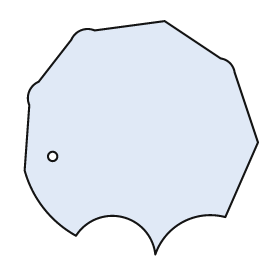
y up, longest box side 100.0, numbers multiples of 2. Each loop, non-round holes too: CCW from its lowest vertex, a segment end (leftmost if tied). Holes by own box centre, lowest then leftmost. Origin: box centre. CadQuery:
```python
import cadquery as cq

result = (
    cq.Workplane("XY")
    .moveTo(6.0, -50.0)
    .threePointArc((18.0, -36.0), (36.0, -34.0))
    .lineTo(50.0, -2.0)
    .lineTo(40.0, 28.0)
    .threePointArc((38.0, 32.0), (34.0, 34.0))
    .lineTo(10.0, 50.0)
    .lineTo(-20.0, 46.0)
    .threePointArc((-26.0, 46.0), (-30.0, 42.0))
    .lineTo(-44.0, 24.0)
    .threePointArc((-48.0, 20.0), (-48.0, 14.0))
    .lineTo(-50.0, -14.0)
    .threePointArc((-42.0, -30.0), (-28.0, -42.0))
    .threePointArc((-8.0, -34.0), (6.0, -50.0))
    .close()
    .moveTo(-38.0, -8.0)
    .circle(2.0)
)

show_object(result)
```